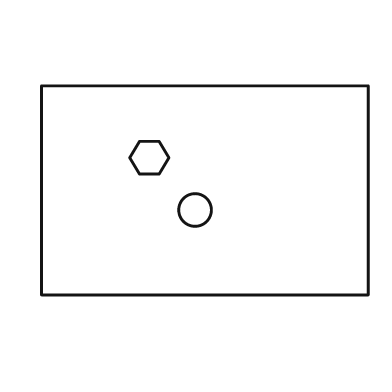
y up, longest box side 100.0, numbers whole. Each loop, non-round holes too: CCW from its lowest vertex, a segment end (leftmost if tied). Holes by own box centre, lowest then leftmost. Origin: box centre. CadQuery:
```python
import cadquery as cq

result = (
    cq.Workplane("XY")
    .moveTo(-50.0, -32.0)
    .lineTo(50.0, -32.0)
    .lineTo(50.0, 32.0)
    .lineTo(-50.0, 32.0)
    .close()
    .moveTo(-3.0, -6.0)
    .circle(5.0)
    .moveTo(-20.0, 5.0)
    .lineTo(-14.0, 5.0)
    .lineTo(-11.0, 10.0)
    .lineTo(-14.0, 15.0)
    .lineTo(-20.0, 15.0)
    .lineTo(-23.0, 10.0)
    .close()
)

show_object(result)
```